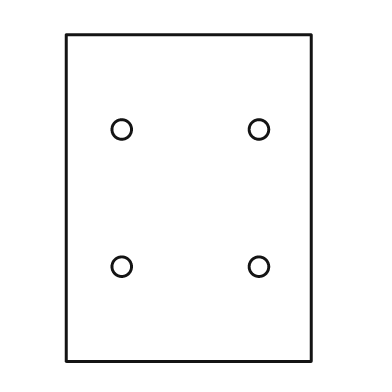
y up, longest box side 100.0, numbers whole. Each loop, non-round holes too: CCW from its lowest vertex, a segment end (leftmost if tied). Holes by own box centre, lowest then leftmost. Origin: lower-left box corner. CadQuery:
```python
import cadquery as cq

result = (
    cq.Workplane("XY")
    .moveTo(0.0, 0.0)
    .lineTo(75.0, 0.0)
    .lineTo(75.0, 100.0)
    .lineTo(0.0, 100.0)
    .close()
    .moveTo(17.0, 29.0)
    .circle(3.0)
    .moveTo(59.0, 29.0)
    .circle(3.0)
    .moveTo(17.0, 71.0)
    .circle(3.0)
    .moveTo(59.0, 71.0)
    .circle(3.0)
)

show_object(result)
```